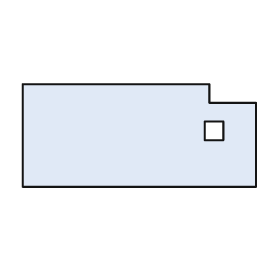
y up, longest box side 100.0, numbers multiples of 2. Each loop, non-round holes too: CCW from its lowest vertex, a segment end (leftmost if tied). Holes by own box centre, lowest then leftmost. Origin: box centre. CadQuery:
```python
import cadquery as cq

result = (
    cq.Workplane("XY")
    .moveTo(-50.0, -22.0)
    .lineTo(50.0, -22.0)
    .lineTo(50.0, 14.0)
    .lineTo(30.0, 14.0)
    .lineTo(30.0, 22.0)
    .lineTo(-50.0, 22.0)
    .close()
    .moveTo(28.0, -2.0)
    .lineTo(36.0, -2.0)
    .lineTo(36.0, 6.0)
    .lineTo(28.0, 6.0)
    .close()
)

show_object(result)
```